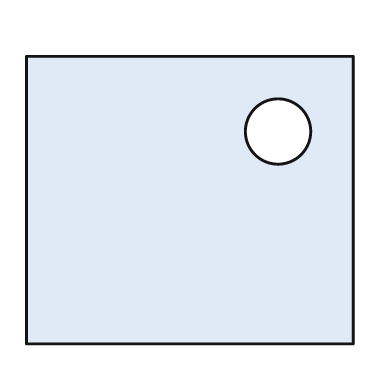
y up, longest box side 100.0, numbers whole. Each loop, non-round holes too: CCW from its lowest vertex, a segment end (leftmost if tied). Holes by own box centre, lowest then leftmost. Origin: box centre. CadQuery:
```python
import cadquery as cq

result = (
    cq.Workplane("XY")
    .moveTo(-50.0, -44.0)
    .lineTo(50.0, -44.0)
    .lineTo(50.0, 44.0)
    .lineTo(-50.0, 44.0)
    .close()
    .moveTo(27.0, 21.0)
    .circle(10.0)
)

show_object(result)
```